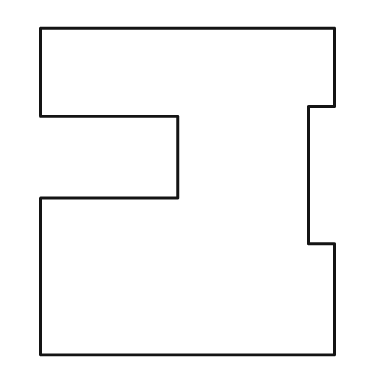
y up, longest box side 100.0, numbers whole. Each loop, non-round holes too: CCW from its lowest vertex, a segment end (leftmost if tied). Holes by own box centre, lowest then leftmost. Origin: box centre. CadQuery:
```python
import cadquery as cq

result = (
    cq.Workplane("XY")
    .moveTo(-45.0, -50.0)
    .lineTo(45.0, -50.0)
    .lineTo(45.0, -16.0)
    .lineTo(37.0, -16.0)
    .lineTo(37.0, 26.0)
    .lineTo(45.0, 26.0)
    .lineTo(45.0, 50.0)
    .lineTo(-45.0, 50.0)
    .lineTo(-45.0, 23.0)
    .lineTo(-3.0, 23.0)
    .lineTo(-3.0, -2.0)
    .lineTo(-45.0, -2.0)
    .close()
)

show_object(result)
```